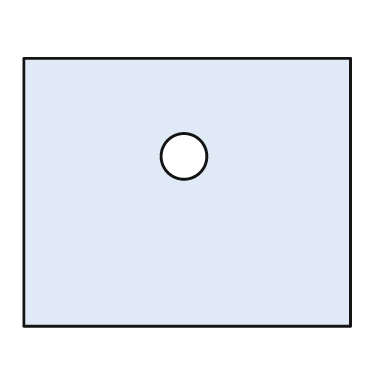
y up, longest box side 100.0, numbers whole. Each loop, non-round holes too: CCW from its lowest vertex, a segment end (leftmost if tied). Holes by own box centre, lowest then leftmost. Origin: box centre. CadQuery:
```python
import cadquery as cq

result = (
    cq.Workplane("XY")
    .moveTo(-50.0, -41.0)
    .lineTo(50.0, -41.0)
    .lineTo(50.0, 41.0)
    .lineTo(-50.0, 41.0)
    .close()
    .moveTo(-1.0, 11.0)
    .circle(7.0)
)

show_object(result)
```